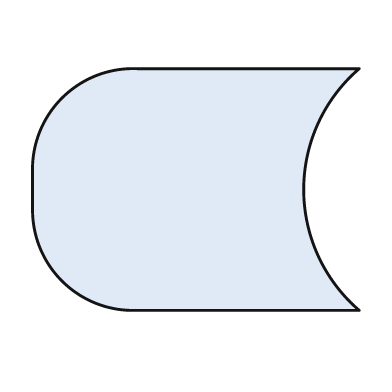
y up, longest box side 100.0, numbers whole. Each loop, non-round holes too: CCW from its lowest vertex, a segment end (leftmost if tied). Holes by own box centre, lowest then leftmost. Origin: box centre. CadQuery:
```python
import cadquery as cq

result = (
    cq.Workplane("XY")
    .moveTo(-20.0, -37.0)
    .lineTo(50.0, -37.0)
    .threePointArc((33.0, 0.0), (50.0, 37.0))
    .lineTo(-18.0, 37.0)
    .threePointArc((-41.0, 28.0), (-50.0, 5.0))
    .lineTo(-50.0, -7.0)
    .threePointArc((-41.0, -28.0), (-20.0, -37.0))
    .close()
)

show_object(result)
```